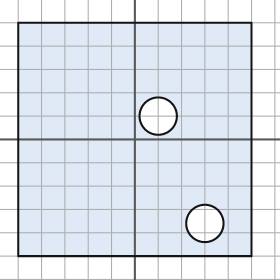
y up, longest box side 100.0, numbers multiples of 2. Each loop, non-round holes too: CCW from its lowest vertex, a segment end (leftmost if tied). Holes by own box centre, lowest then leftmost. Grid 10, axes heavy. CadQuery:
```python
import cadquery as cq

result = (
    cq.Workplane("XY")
    .moveTo(-50.0, -50.0)
    .lineTo(50.0, -50.0)
    .lineTo(50.0, 50.0)
    .lineTo(-50.0, 50.0)
    .close()
    .moveTo(30.0, -36.0)
    .circle(8.0)
    .moveTo(10.0, 10.0)
    .circle(8.0)
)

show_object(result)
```